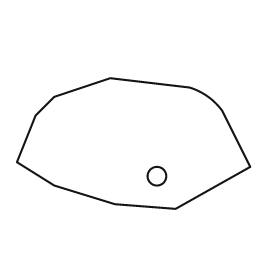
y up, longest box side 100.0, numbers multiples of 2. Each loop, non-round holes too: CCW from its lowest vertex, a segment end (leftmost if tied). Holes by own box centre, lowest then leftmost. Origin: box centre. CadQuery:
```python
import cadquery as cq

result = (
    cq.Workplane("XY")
    .moveTo(18.0, -28.0)
    .lineTo(50.0, -10.0)
    .lineTo(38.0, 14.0)
    .threePointArc((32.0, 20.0), (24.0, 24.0))
    .lineTo(-10.0, 28.0)
    .lineTo(-34.0, 20.0)
    .lineTo(-42.0, 12.0)
    .lineTo(-50.0, -8.0)
    .lineTo(-34.0, -18.0)
    .lineTo(-8.0, -26.0)
    .close()
    .moveTo(10.0, -14.0)
    .circle(4.0)
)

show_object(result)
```